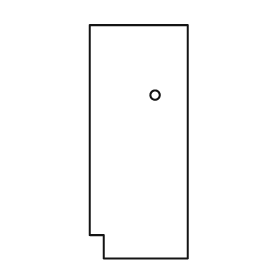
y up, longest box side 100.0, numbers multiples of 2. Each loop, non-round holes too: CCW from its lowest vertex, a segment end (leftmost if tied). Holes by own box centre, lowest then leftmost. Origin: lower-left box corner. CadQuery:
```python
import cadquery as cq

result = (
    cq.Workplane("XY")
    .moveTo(6.0, 0.0)
    .lineTo(42.0, 0.0)
    .lineTo(42.0, 100.0)
    .lineTo(0.0, 100.0)
    .lineTo(0.0, 10.0)
    .lineTo(6.0, 10.0)
    .close()
    .moveTo(28.0, 70.0)
    .circle(2.0)
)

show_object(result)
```